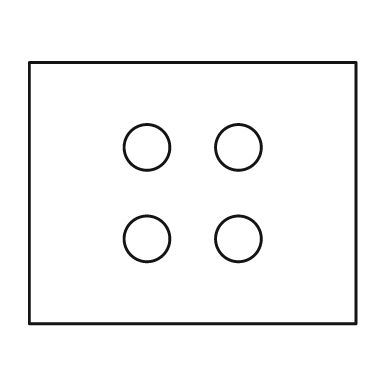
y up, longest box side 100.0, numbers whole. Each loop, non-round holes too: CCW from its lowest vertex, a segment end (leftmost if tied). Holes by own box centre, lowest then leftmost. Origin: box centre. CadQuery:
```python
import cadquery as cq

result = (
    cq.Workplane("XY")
    .moveTo(-50.0, -40.0)
    .lineTo(50.0, -40.0)
    .lineTo(50.0, 40.0)
    .lineTo(-50.0, 40.0)
    .close()
    .moveTo(-14.0, -14.0)
    .circle(7.0)
    .moveTo(14.0, -14.0)
    .circle(7.0)
    .moveTo(-14.0, 14.0)
    .circle(7.0)
    .moveTo(14.0, 14.0)
    .circle(7.0)
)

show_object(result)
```